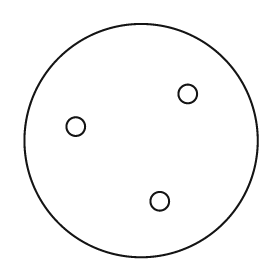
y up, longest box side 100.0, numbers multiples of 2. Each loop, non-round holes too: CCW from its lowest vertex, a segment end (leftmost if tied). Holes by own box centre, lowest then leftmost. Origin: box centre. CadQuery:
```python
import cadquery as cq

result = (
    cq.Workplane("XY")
    .moveTo(0.0, 0.0)
    .circle(50.0)
    .moveTo(8.0, -26.0)
    .circle(4.0)
    .moveTo(-28.0, 6.0)
    .circle(4.0)
    .moveTo(20.0, 20.0)
    .circle(4.0)
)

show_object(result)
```